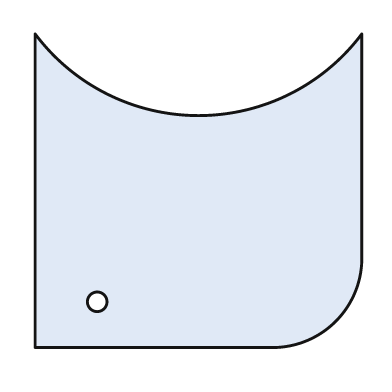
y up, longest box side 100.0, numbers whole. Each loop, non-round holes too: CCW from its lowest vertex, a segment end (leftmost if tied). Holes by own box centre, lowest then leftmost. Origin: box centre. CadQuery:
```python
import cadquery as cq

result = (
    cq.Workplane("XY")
    .moveTo(-50.0, -48.0)
    .lineTo(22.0, -48.0)
    .threePointArc((42.0, -40.0), (50.0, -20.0))
    .lineTo(50.0, 48.0)
    .threePointArc((0.0, 23.0), (-50.0, 48.0))
    .close()
    .moveTo(-31.0, -34.0)
    .circle(3.0)
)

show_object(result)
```